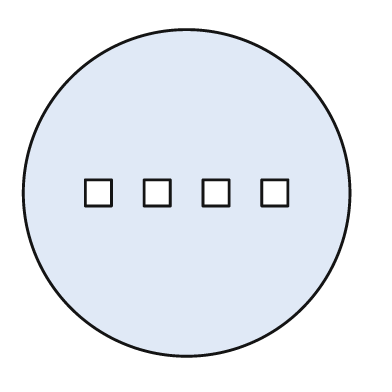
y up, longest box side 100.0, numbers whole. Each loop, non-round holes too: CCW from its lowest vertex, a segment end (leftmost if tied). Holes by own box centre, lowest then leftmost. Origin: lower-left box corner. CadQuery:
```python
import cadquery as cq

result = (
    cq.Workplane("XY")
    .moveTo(50.0, 50.0)
    .circle(50.0)
    .moveTo(19.0, 46.0)
    .lineTo(27.0, 46.0)
    .lineTo(27.0, 54.0)
    .lineTo(19.0, 54.0)
    .close()
    .moveTo(37.0, 46.0)
    .lineTo(45.0, 46.0)
    .lineTo(45.0, 54.0)
    .lineTo(37.0, 54.0)
    .close()
    .moveTo(55.0, 46.0)
    .lineTo(63.0, 46.0)
    .lineTo(63.0, 54.0)
    .lineTo(55.0, 54.0)
    .close()
    .moveTo(73.0, 46.0)
    .lineTo(81.0, 46.0)
    .lineTo(81.0, 54.0)
    .lineTo(73.0, 54.0)
    .close()
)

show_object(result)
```